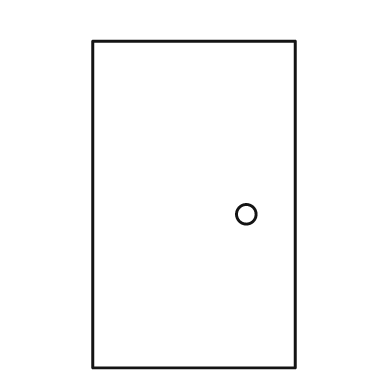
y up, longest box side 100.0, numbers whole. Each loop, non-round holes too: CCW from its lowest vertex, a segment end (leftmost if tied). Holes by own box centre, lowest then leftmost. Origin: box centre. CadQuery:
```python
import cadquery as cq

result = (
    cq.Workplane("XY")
    .moveTo(-31.0, -50.0)
    .lineTo(31.0, -50.0)
    .lineTo(31.0, 50.0)
    .lineTo(-31.0, 50.0)
    .close()
    .moveTo(16.0, -3.0)
    .circle(3.0)
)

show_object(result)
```